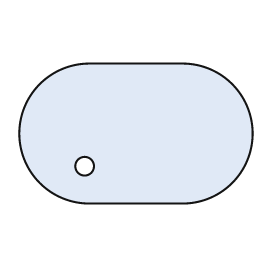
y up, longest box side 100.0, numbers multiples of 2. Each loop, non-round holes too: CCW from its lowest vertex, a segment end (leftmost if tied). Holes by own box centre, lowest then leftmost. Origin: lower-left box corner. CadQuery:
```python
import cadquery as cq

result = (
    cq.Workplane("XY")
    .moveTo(30.0, 0.0)
    .lineTo(70.0, 0.0)
    .threePointArc((100.0, 30.0), (70.0, 60.0))
    .lineTo(30.0, 60.0)
    .threePointArc((0.0, 30.0), (30.0, 0.0))
    .close()
    .moveTo(28.0, 16.0)
    .circle(4.0)
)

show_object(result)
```